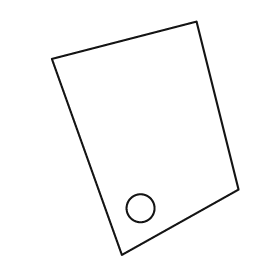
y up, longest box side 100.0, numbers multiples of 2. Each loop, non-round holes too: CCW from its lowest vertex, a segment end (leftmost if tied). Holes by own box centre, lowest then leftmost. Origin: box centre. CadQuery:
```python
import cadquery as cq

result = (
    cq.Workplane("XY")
    .moveTo(-10.0, -50.0)
    .lineTo(40.0, -22.0)
    .lineTo(22.0, 50.0)
    .lineTo(-40.0, 34.0)
    .close()
    .moveTo(-2.0, -30.0)
    .circle(6.0)
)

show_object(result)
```